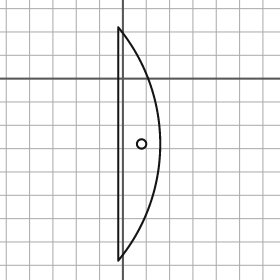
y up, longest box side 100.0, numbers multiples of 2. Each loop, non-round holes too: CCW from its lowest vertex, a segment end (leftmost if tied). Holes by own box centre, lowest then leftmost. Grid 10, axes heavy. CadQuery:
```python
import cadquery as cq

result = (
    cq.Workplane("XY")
    .moveTo(-2.0, -78.0)
    .threePointArc((16.0, -28.0), (-2.0, 22.0))
    .close()
    .moveTo(8.0, -28.0)
    .circle(2.0)
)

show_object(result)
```